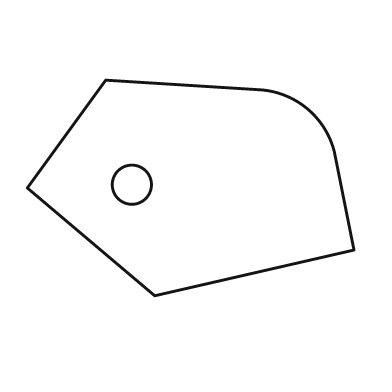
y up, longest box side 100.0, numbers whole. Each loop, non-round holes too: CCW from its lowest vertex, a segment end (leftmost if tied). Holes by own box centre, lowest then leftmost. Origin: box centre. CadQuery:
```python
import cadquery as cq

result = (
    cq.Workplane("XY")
    .moveTo(-11.0, -33.0)
    .lineTo(50.0, -19.0)
    .lineTo(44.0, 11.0)
    .threePointArc((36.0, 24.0), (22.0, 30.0))
    .lineTo(-26.0, 33.0)
    .lineTo(-50.0, 0.0)
    .close()
    .moveTo(-18.0, 1.0)
    .circle(6.0)
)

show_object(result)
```